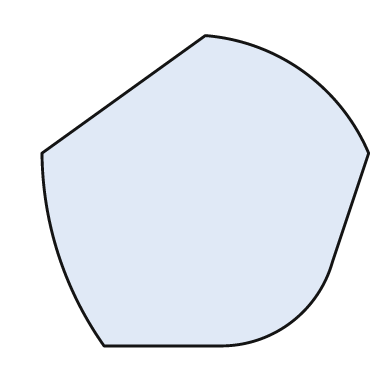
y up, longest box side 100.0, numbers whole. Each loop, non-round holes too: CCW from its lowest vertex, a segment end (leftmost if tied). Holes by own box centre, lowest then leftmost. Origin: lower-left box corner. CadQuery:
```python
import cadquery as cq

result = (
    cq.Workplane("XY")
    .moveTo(19.0, 0.0)
    .lineTo(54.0, 0.0)
    .threePointArc((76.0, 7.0), (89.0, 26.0))
    .lineTo(100.0, 59.0)
    .threePointArc((80.0, 84.0), (50.0, 95.0))
    .lineTo(0.0, 59.0)
    .threePointArc((5.0, 28.0), (19.0, 0.0))
    .close()
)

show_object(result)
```